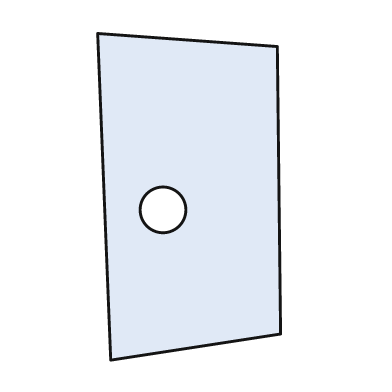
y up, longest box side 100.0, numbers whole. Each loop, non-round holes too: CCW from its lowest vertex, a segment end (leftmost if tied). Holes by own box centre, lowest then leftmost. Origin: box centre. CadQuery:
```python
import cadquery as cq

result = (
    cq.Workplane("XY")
    .moveTo(-24.0, -50.0)
    .lineTo(28.0, -42.0)
    .lineTo(27.0, 46.0)
    .lineTo(-28.0, 50.0)
    .close()
    .moveTo(-8.0, -4.0)
    .circle(7.0)
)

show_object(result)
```